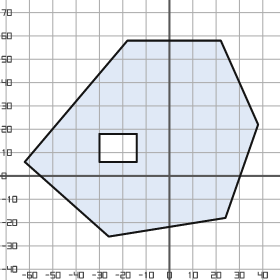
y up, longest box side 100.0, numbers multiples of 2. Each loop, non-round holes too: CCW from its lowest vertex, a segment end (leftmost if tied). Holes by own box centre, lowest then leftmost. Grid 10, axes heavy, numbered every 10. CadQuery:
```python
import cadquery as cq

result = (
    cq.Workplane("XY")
    .moveTo(-26.0, -26.0)
    .lineTo(24.0, -18.0)
    .lineTo(38.0, 22.0)
    .lineTo(22.0, 58.0)
    .lineTo(-18.0, 58.0)
    .lineTo(-62.0, 6.0)
    .close()
    .moveTo(-30.0, 6.0)
    .lineTo(-14.0, 6.0)
    .lineTo(-14.0, 18.0)
    .lineTo(-30.0, 18.0)
    .close()
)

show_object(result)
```